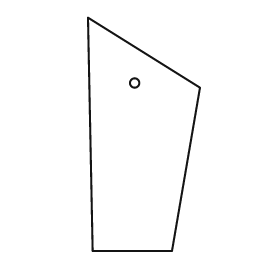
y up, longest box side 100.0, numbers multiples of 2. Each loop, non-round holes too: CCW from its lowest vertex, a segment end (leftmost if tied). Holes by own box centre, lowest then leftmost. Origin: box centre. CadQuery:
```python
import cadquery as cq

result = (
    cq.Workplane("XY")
    .moveTo(-22.0, -50.0)
    .lineTo(12.0, -50.0)
    .lineTo(24.0, 20.0)
    .lineTo(-24.0, 50.0)
    .close()
    .moveTo(-4.0, 22.0)
    .circle(2.0)
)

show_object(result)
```